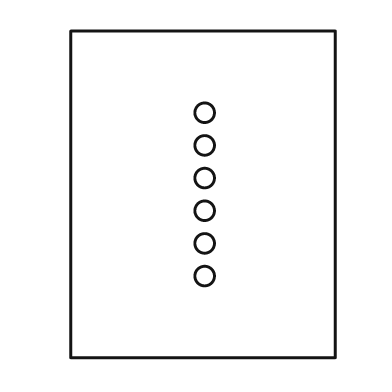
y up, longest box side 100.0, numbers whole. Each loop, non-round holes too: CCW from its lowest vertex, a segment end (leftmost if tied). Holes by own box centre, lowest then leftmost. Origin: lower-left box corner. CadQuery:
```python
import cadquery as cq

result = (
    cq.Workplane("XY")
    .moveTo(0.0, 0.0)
    .lineTo(81.0, 0.0)
    .lineTo(81.0, 100.0)
    .lineTo(0.0, 100.0)
    .close()
    .moveTo(41.0, 25.0)
    .circle(3.0)
    .moveTo(41.0, 35.0)
    .circle(3.0)
    .moveTo(41.0, 45.0)
    .circle(3.0)
    .moveTo(41.0, 55.0)
    .circle(3.0)
    .moveTo(41.0, 65.0)
    .circle(3.0)
    .moveTo(41.0, 75.0)
    .circle(3.0)
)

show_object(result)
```